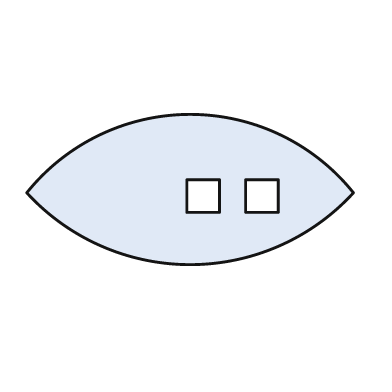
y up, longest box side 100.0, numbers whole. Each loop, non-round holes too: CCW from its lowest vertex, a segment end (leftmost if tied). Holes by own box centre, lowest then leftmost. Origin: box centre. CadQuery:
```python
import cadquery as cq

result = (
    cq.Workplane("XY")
    .moveTo(-50.0, -1.0)
    .threePointArc((0.0, -23.0), (50.0, -1.0))
    .threePointArc((0.0, 23.0), (-50.0, -1.0))
    .close()
    .moveTo(-1.0, -7.0)
    .lineTo(9.0, -7.0)
    .lineTo(9.0, 3.0)
    .lineTo(-1.0, 3.0)
    .close()
    .moveTo(17.0, -7.0)
    .lineTo(27.0, -7.0)
    .lineTo(27.0, 3.0)
    .lineTo(17.0, 3.0)
    .close()
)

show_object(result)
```